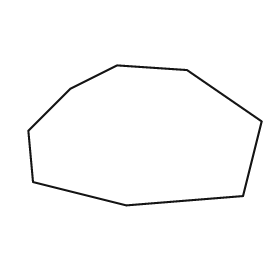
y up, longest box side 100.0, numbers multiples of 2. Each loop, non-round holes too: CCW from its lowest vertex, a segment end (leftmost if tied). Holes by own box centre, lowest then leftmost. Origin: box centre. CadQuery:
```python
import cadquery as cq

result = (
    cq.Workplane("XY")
    .moveTo(-8.0, -30.0)
    .lineTo(42.0, -26.0)
    .lineTo(50.0, 6.0)
    .lineTo(18.0, 28.0)
    .lineTo(-12.0, 30.0)
    .lineTo(-32.0, 20.0)
    .lineTo(-50.0, 2.0)
    .lineTo(-48.0, -20.0)
    .close()
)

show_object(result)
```